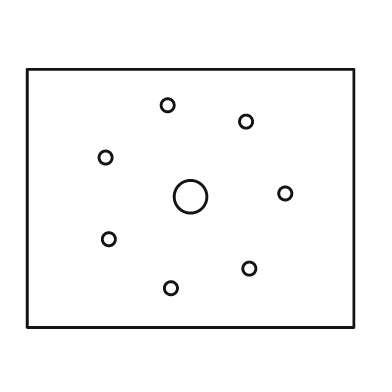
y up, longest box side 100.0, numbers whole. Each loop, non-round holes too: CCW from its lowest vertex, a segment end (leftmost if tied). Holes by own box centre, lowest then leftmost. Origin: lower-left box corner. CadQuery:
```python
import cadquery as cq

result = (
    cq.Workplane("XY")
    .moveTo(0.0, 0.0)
    .lineTo(100.0, 0.0)
    .lineTo(100.0, 79.0)
    .lineTo(0.0, 79.0)
    .close()
    .moveTo(44.0, 12.0)
    .circle(2.0)
    .moveTo(68.0, 18.0)
    .circle(2.0)
    .moveTo(25.0, 27.0)
    .circle(2.0)
    .moveTo(50.0, 40.0)
    .circle(5.0)
    .moveTo(79.0, 41.0)
    .circle(2.0)
    .moveTo(24.0, 52.0)
    .circle(2.0)
    .moveTo(67.0, 63.0)
    .circle(2.0)
    .moveTo(43.0, 68.0)
    .circle(2.0)
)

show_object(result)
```